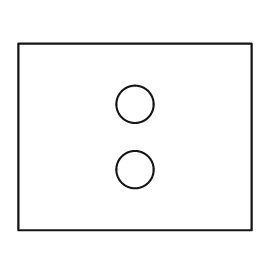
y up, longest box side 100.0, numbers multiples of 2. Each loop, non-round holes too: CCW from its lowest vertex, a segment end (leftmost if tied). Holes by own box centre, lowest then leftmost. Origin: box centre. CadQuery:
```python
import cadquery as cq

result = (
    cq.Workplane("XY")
    .moveTo(-50.0, -40.0)
    .lineTo(50.0, -40.0)
    .lineTo(50.0, 40.0)
    .lineTo(-50.0, 40.0)
    .close()
    .moveTo(0.0, -14.0)
    .circle(8.0)
    .moveTo(0.0, 14.0)
    .circle(8.0)
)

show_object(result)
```